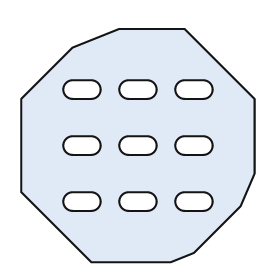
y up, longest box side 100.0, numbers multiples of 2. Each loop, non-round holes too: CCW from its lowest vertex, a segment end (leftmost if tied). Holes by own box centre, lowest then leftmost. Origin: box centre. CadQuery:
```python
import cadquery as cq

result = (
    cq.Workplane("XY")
    .moveTo(-20.0, -50.0)
    .lineTo(14.0, -50.0)
    .lineTo(24.0, -46.0)
    .lineTo(44.0, -26.0)
    .lineTo(50.0, -12.0)
    .lineTo(50.0, 20.0)
    .lineTo(20.0, 50.0)
    .lineTo(-8.0, 50.0)
    .lineTo(-28.0, 42.0)
    .lineTo(-50.0, 20.0)
    .lineTo(-50.0, -20.0)
    .close()
    .moveTo(-28.0, -28.0)
    .lineTo(-20.0, -28.0)
    .threePointArc((-16.0, -24.0), (-20.0, -20.0))
    .lineTo(-28.0, -20.0)
    .threePointArc((-32.0, -24.0), (-28.0, -28.0))
    .close()
    .moveTo(-4.0, -28.0)
    .lineTo(4.0, -28.0)
    .threePointArc((8.0, -24.0), (4.0, -20.0))
    .lineTo(-4.0, -20.0)
    .threePointArc((-8.0, -24.0), (-4.0, -28.0))
    .close()
    .moveTo(20.0, -28.0)
    .lineTo(28.0, -28.0)
    .threePointArc((32.0, -24.0), (28.0, -20.0))
    .lineTo(20.0, -20.0)
    .threePointArc((16.0, -24.0), (20.0, -28.0))
    .close()
    .moveTo(-28.0, -4.0)
    .lineTo(-20.0, -4.0)
    .threePointArc((-16.0, 0.0), (-20.0, 4.0))
    .lineTo(-28.0, 4.0)
    .threePointArc((-32.0, 0.0), (-28.0, -4.0))
    .close()
    .moveTo(-4.0, -4.0)
    .lineTo(4.0, -4.0)
    .threePointArc((8.0, 0.0), (4.0, 4.0))
    .lineTo(-4.0, 4.0)
    .threePointArc((-8.0, 0.0), (-4.0, -4.0))
    .close()
    .moveTo(20.0, -4.0)
    .lineTo(28.0, -4.0)
    .threePointArc((32.0, 0.0), (28.0, 4.0))
    .lineTo(20.0, 4.0)
    .threePointArc((16.0, 0.0), (20.0, -4.0))
    .close()
    .moveTo(-28.0, 20.0)
    .lineTo(-20.0, 20.0)
    .threePointArc((-16.0, 24.0), (-20.0, 28.0))
    .lineTo(-28.0, 28.0)
    .threePointArc((-32.0, 24.0), (-28.0, 20.0))
    .close()
    .moveTo(-4.0, 20.0)
    .lineTo(4.0, 20.0)
    .threePointArc((8.0, 24.0), (4.0, 28.0))
    .lineTo(-4.0, 28.0)
    .threePointArc((-8.0, 24.0), (-4.0, 20.0))
    .close()
    .moveTo(20.0, 20.0)
    .lineTo(28.0, 20.0)
    .threePointArc((32.0, 24.0), (28.0, 28.0))
    .lineTo(20.0, 28.0)
    .threePointArc((16.0, 24.0), (20.0, 20.0))
    .close()
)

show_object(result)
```